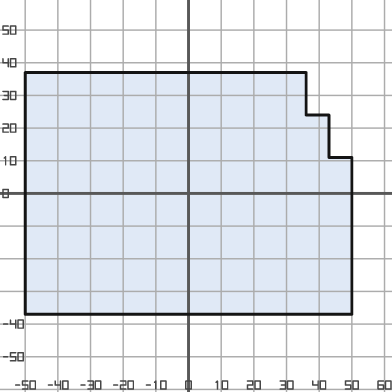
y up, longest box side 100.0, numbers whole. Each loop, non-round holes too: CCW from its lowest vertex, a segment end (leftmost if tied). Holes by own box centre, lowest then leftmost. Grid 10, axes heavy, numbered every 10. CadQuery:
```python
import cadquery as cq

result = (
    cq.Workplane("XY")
    .moveTo(-50.0, -37.0)
    .lineTo(50.0, -37.0)
    .lineTo(50.0, 11.0)
    .lineTo(43.0, 11.0)
    .lineTo(43.0, 24.0)
    .lineTo(36.0, 24.0)
    .lineTo(36.0, 37.0)
    .lineTo(-50.0, 37.0)
    .close()
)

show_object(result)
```